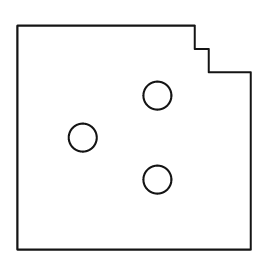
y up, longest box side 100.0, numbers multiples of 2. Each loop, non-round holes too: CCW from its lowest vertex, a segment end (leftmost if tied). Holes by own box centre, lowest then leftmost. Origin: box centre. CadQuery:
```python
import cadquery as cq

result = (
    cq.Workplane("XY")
    .moveTo(-50.0, -48.0)
    .lineTo(50.0, -48.0)
    .lineTo(50.0, 28.0)
    .lineTo(32.0, 28.0)
    .lineTo(32.0, 38.0)
    .lineTo(26.0, 38.0)
    .lineTo(26.0, 48.0)
    .lineTo(-50.0, 48.0)
    .close()
    .moveTo(10.0, -18.0)
    .circle(6.0)
    .moveTo(-22.0, 0.0)
    .circle(6.0)
    .moveTo(10.0, 18.0)
    .circle(6.0)
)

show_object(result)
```